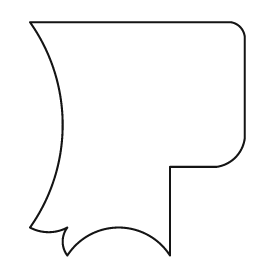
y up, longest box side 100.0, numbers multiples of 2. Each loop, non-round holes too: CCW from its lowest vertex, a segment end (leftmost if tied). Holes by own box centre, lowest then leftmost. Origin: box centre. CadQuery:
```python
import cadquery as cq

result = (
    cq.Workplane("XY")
    .moveTo(-30.0, -50.0)
    .threePointArc((-8.0, -38.0), (14.0, -50.0))
    .lineTo(14.0, -12.0)
    .lineTo(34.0, -12.0)
    .threePointArc((42.0, -8.0), (46.0, 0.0))
    .lineTo(46.0, 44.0)
    .threePointArc((44.0, 48.0), (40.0, 50.0))
    .lineTo(-46.0, 50.0)
    .threePointArc((-32.0, 6.0), (-46.0, -38.0))
    .threePointArc((-38.0, -40.0), (-30.0, -38.0))
    .threePointArc((-32.0, -44.0), (-30.0, -50.0))
    .close()
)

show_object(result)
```